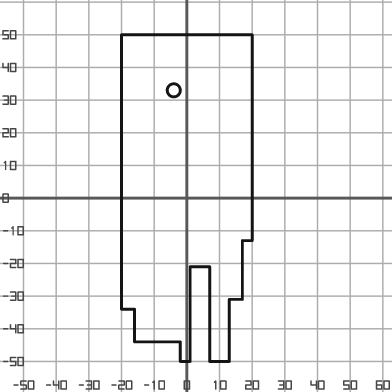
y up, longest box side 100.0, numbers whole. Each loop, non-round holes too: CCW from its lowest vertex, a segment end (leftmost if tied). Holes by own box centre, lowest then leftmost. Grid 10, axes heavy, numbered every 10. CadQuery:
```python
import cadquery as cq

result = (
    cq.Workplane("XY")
    .moveTo(-2.0, -50.0)
    .lineTo(1.0, -50.0)
    .lineTo(1.0, -21.0)
    .lineTo(7.0, -21.0)
    .lineTo(7.0, -50.0)
    .lineTo(13.0, -50.0)
    .lineTo(13.0, -31.0)
    .lineTo(17.0, -31.0)
    .lineTo(17.0, -13.0)
    .lineTo(20.0, -13.0)
    .lineTo(20.0, 50.0)
    .lineTo(-20.0, 50.0)
    .lineTo(-20.0, -34.0)
    .lineTo(-16.0, -34.0)
    .lineTo(-16.0, -44.0)
    .lineTo(-2.0, -44.0)
    .close()
    .moveTo(-4.0, 33.0)
    .circle(2.0)
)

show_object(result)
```